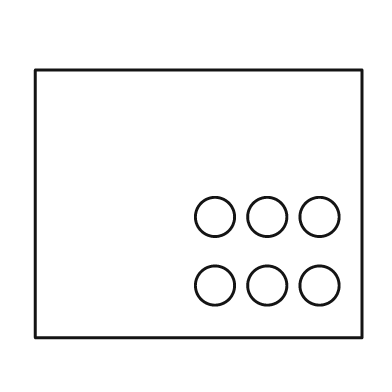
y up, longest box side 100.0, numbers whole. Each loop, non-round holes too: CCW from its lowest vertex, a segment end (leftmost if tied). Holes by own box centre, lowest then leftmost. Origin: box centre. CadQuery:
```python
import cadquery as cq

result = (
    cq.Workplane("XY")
    .moveTo(-50.0, -41.0)
    .lineTo(50.0, -41.0)
    .lineTo(50.0, 41.0)
    .lineTo(-50.0, 41.0)
    .close()
    .moveTo(5.0, -25.0)
    .circle(6.0)
    .moveTo(21.0, -25.0)
    .circle(6.0)
    .moveTo(37.0, -25.0)
    .circle(6.0)
    .moveTo(5.0, -4.0)
    .circle(6.0)
    .moveTo(21.0, -4.0)
    .circle(6.0)
    .moveTo(37.0, -4.0)
    .circle(6.0)
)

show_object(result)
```